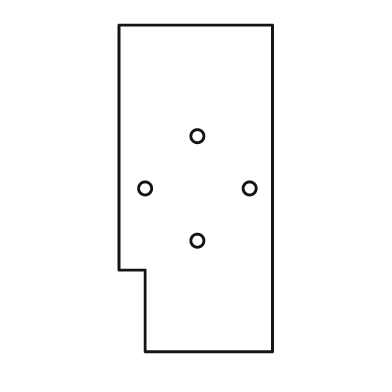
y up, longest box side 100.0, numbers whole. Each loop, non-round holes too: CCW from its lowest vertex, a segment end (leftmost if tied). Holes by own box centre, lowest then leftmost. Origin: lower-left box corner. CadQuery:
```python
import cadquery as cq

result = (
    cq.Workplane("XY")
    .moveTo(8.0, 0.0)
    .lineTo(47.0, 0.0)
    .lineTo(47.0, 100.0)
    .lineTo(0.0, 100.0)
    .lineTo(0.0, 25.0)
    .lineTo(8.0, 25.0)
    .close()
    .moveTo(24.0, 34.0)
    .circle(2.0)
    .moveTo(8.0, 50.0)
    .circle(2.0)
    .moveTo(40.0, 50.0)
    .circle(2.0)
    .moveTo(24.0, 66.0)
    .circle(2.0)
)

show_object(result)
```